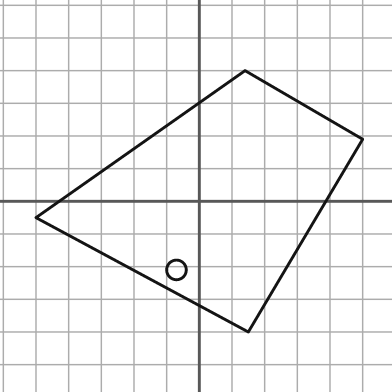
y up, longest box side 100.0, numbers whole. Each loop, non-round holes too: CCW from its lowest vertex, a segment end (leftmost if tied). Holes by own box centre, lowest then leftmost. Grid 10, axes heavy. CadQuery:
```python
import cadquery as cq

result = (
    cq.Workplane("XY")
    .moveTo(15.0, -40.0)
    .lineTo(50.0, 19.0)
    .lineTo(14.0, 40.0)
    .lineTo(-50.0, -5.0)
    .close()
    .moveTo(-7.0, -21.0)
    .circle(3.0)
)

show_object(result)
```